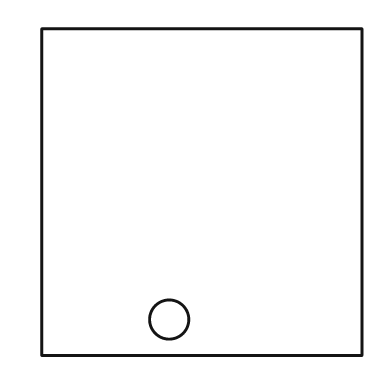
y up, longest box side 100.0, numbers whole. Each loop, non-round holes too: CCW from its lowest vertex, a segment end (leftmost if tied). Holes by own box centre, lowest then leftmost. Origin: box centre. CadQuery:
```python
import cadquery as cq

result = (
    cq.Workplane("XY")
    .moveTo(-49.0, -50.0)
    .lineTo(49.0, -50.0)
    .lineTo(49.0, 50.0)
    .lineTo(-49.0, 50.0)
    .close()
    .moveTo(-10.0, -39.0)
    .circle(6.0)
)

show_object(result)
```